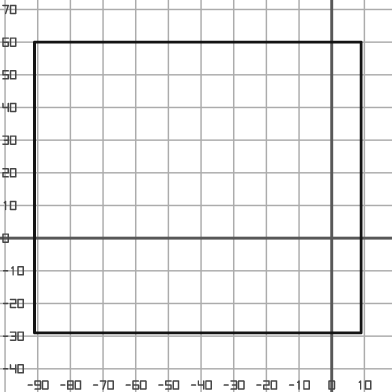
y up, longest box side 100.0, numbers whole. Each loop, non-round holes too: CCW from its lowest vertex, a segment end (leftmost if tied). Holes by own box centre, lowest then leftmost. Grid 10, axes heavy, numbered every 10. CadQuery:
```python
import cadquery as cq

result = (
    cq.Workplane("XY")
    .moveTo(-91.0, -29.0)
    .lineTo(9.0, -29.0)
    .lineTo(9.0, 60.0)
    .lineTo(-91.0, 60.0)
    .close()
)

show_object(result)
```